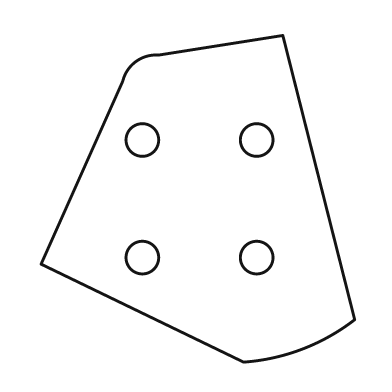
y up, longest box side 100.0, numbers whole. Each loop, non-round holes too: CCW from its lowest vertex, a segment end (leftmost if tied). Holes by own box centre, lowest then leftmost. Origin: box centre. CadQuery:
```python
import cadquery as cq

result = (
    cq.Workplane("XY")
    .moveTo(14.0, -50.0)
    .threePointArc((32.0, -46.0), (48.0, -37.0))
    .lineTo(26.0, 50.0)
    .lineTo(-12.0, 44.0)
    .threePointArc((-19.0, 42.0), (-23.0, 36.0))
    .lineTo(-48.0, -20.0)
    .close()
    .moveTo(-17.0, -18.0)
    .circle(5.0)
    .moveTo(18.0, -18.0)
    .circle(5.0)
    .moveTo(-17.0, 18.0)
    .circle(5.0)
    .moveTo(18.0, 18.0)
    .circle(5.0)
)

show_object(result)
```